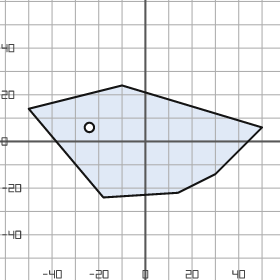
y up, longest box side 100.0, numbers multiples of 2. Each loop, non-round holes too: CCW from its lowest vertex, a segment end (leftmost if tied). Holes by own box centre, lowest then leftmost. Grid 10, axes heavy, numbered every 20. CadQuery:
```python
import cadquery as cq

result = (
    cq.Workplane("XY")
    .moveTo(-18.0, -24.0)
    .lineTo(14.0, -22.0)
    .lineTo(30.0, -14.0)
    .lineTo(50.0, 6.0)
    .lineTo(-10.0, 24.0)
    .lineTo(-50.0, 14.0)
    .close()
    .moveTo(-24.0, 6.0)
    .circle(2.0)
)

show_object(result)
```